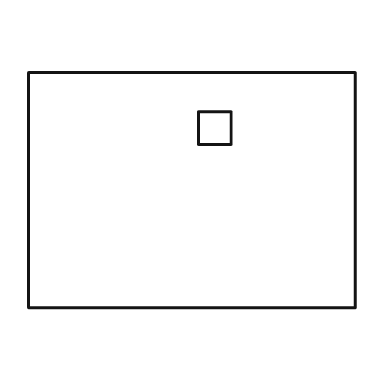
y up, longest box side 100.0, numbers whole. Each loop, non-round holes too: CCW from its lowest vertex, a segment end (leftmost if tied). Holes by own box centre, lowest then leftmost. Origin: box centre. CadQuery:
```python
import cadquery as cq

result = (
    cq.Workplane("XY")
    .moveTo(-50.0, -36.0)
    .lineTo(50.0, -36.0)
    .lineTo(50.0, 36.0)
    .lineTo(-50.0, 36.0)
    .close()
    .moveTo(2.0, 14.0)
    .lineTo(12.0, 14.0)
    .lineTo(12.0, 24.0)
    .lineTo(2.0, 24.0)
    .close()
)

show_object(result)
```